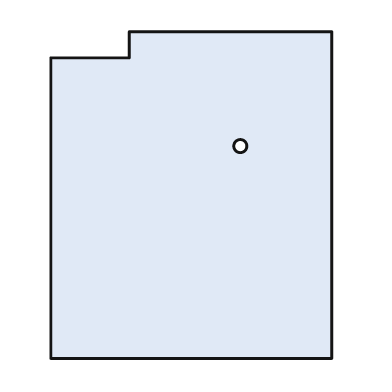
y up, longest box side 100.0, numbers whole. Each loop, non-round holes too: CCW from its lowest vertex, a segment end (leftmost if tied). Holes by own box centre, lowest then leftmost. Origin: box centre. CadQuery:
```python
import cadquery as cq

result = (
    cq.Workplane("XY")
    .moveTo(-43.0, -50.0)
    .lineTo(43.0, -50.0)
    .lineTo(43.0, 50.0)
    .lineTo(-19.0, 50.0)
    .lineTo(-19.0, 42.0)
    .lineTo(-43.0, 42.0)
    .close()
    .moveTo(15.0, 15.0)
    .circle(2.0)
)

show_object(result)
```